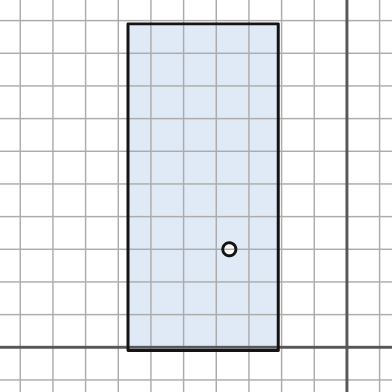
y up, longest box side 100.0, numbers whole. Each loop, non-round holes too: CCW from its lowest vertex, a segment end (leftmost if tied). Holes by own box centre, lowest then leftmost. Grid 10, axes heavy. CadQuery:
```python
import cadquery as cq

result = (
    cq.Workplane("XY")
    .moveTo(-67.0, -1.0)
    .lineTo(-21.0, -1.0)
    .lineTo(-21.0, 99.0)
    .lineTo(-67.0, 99.0)
    .close()
    .moveTo(-36.0, 30.0)
    .circle(2.0)
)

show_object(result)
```